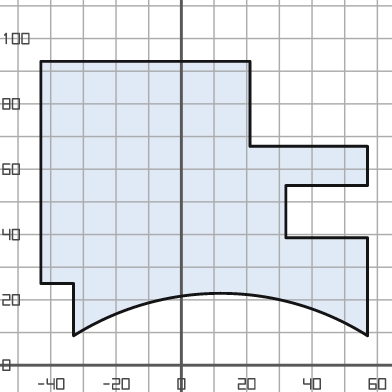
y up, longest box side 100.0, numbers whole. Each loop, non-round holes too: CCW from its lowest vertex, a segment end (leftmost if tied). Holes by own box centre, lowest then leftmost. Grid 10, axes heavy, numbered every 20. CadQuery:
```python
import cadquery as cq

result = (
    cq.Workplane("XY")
    .moveTo(-33.0, 9.0)
    .threePointArc((12.0, 22.0), (57.0, 9.0))
    .lineTo(57.0, 39.0)
    .lineTo(32.0, 39.0)
    .lineTo(32.0, 55.0)
    .lineTo(57.0, 55.0)
    .lineTo(57.0, 67.0)
    .lineTo(21.0, 67.0)
    .lineTo(21.0, 93.0)
    .lineTo(-43.0, 93.0)
    .lineTo(-43.0, 25.0)
    .lineTo(-33.0, 25.0)
    .close()
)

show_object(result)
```